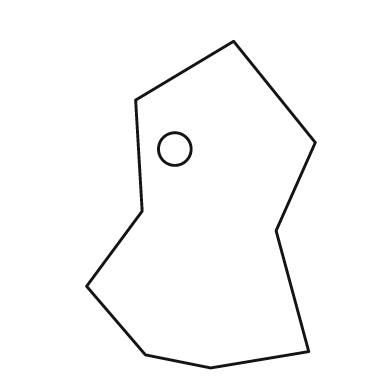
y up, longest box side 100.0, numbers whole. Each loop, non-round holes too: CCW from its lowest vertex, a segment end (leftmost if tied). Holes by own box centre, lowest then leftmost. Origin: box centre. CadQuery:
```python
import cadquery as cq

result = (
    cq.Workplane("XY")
    .moveTo(3.0, -50.0)
    .lineTo(33.0, -45.0)
    .lineTo(23.0, -8.0)
    .lineTo(35.0, 19.0)
    .lineTo(10.0, 50.0)
    .lineTo(-20.0, 32.0)
    .lineTo(-18.0, -2.0)
    .lineTo(-35.0, -25.0)
    .lineTo(-17.0, -46.0)
    .close()
    .moveTo(-8.0, 17.0)
    .circle(5.0)
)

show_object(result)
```